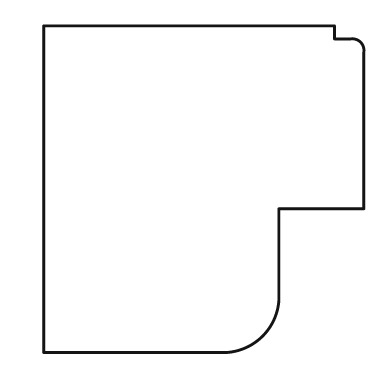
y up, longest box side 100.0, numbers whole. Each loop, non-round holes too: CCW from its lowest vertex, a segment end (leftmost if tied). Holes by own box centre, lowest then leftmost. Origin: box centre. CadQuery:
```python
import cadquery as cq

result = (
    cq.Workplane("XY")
    .moveTo(-49.0, -50.0)
    .lineTo(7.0, -50.0)
    .threePointArc((18.0, -45.0), (23.0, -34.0))
    .lineTo(23.0, -6.0)
    .lineTo(49.0, -6.0)
    .lineTo(49.0, 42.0)
    .threePointArc((48.0, 45.0), (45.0, 46.0))
    .lineTo(40.0, 46.0)
    .lineTo(40.0, 50.0)
    .lineTo(-49.0, 50.0)
    .close()
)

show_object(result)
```